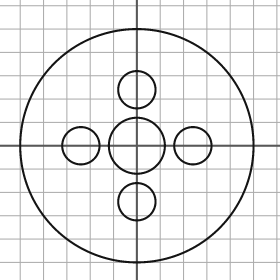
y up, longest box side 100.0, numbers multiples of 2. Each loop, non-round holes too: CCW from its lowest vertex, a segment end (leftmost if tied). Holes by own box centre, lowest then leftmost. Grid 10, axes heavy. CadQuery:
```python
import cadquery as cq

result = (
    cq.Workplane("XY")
    .moveTo(0.0, 0.0)
    .circle(50.0)
    .moveTo(0.0, -24.0)
    .circle(8.0)
    .moveTo(-24.0, 0.0)
    .circle(8.0)
    .moveTo(0.0, 0.0)
    .circle(12.0)
    .moveTo(24.0, 0.0)
    .circle(8.0)
    .moveTo(0.0, 24.0)
    .circle(8.0)
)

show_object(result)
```